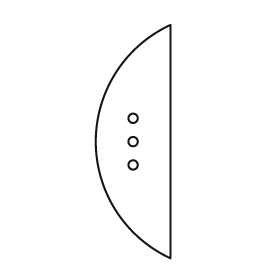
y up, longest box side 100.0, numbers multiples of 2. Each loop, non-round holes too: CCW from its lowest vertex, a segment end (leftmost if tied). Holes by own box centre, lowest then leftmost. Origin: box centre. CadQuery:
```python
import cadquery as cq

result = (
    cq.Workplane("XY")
    .moveTo(16.0, -50.0)
    .lineTo(16.0, 50.0)
    .threePointArc((-16.0, 0.0), (16.0, -50.0))
    .close()
    .moveTo(0.0, -10.0)
    .circle(2.0)
    .moveTo(0.0, 0.0)
    .circle(2.0)
    .moveTo(0.0, 10.0)
    .circle(2.0)
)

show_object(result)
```